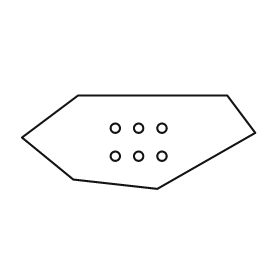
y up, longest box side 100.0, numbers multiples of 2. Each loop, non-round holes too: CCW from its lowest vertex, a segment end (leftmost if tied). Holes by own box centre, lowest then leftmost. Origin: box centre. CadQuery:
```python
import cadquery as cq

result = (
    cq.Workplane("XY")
    .moveTo(8.0, -20.0)
    .lineTo(50.0, 4.0)
    .lineTo(38.0, 20.0)
    .lineTo(-26.0, 20.0)
    .lineTo(-50.0, 2.0)
    .lineTo(-28.0, -16.0)
    .close()
    .moveTo(-10.0, -6.0)
    .circle(2.0)
    .moveTo(0.0, -6.0)
    .circle(2.0)
    .moveTo(10.0, -6.0)
    .circle(2.0)
    .moveTo(-10.0, 6.0)
    .circle(2.0)
    .moveTo(0.0, 6.0)
    .circle(2.0)
    .moveTo(10.0, 6.0)
    .circle(2.0)
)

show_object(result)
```